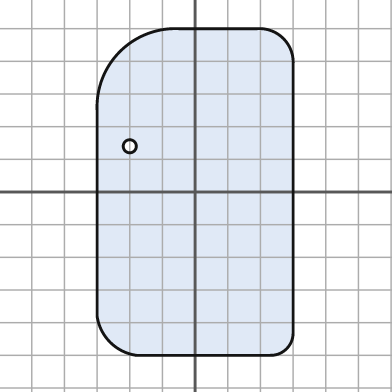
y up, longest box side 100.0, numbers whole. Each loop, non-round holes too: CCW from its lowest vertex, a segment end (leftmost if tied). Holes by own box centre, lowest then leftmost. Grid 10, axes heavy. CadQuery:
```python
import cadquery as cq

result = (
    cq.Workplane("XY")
    .moveTo(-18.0, -50.0)
    .lineTo(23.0, -50.0)
    .threePointArc((28.0, -48.0), (30.0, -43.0))
    .lineTo(30.0, 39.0)
    .threePointArc((27.0, 47.0), (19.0, 50.0))
    .lineTo(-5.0, 50.0)
    .threePointArc((-23.0, 43.0), (-30.0, 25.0))
    .lineTo(-30.0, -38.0)
    .threePointArc((-26.0, -46.0), (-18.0, -50.0))
    .close()
    .moveTo(-20.0, 14.0)
    .circle(2.0)
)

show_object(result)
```